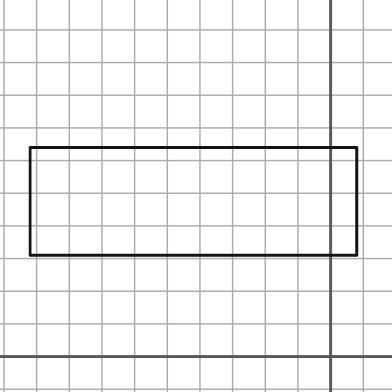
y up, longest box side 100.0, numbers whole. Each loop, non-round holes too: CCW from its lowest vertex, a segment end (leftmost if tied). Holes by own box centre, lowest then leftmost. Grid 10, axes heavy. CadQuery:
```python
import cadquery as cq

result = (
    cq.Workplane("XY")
    .moveTo(-92.0, 31.0)
    .lineTo(8.0, 31.0)
    .lineTo(8.0, 64.0)
    .lineTo(-92.0, 64.0)
    .close()
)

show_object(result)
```